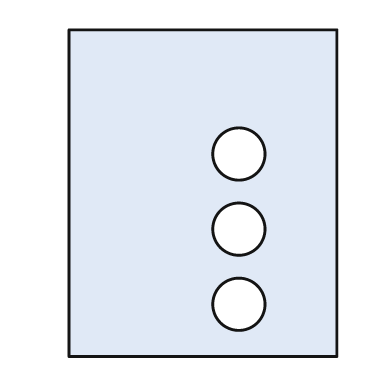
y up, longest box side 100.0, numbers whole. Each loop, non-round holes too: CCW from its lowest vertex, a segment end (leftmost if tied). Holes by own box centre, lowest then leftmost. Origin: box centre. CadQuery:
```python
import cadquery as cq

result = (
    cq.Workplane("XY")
    .moveTo(-41.0, -50.0)
    .lineTo(41.0, -50.0)
    .lineTo(41.0, 50.0)
    .lineTo(-41.0, 50.0)
    .close()
    .moveTo(11.0, -34.0)
    .circle(8.0)
    .moveTo(11.0, -11.0)
    .circle(8.0)
    .moveTo(11.0, 12.0)
    .circle(8.0)
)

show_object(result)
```